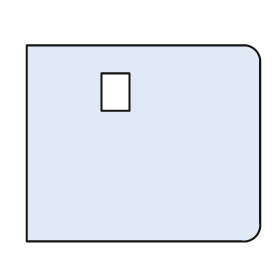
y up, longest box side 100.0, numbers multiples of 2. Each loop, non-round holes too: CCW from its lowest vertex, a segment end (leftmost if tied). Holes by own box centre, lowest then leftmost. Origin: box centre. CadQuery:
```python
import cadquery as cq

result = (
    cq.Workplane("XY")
    .moveTo(-50.0, -42.0)
    .lineTo(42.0, -42.0)
    .threePointArc((48.0, -40.0), (50.0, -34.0))
    .lineTo(50.0, 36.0)
    .threePointArc((48.0, 40.0), (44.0, 42.0))
    .lineTo(-50.0, 42.0)
    .close()
    .moveTo(-18.0, 14.0)
    .lineTo(-6.0, 14.0)
    .lineTo(-6.0, 30.0)
    .lineTo(-18.0, 30.0)
    .close()
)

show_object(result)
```